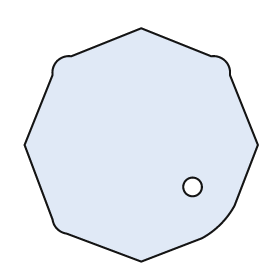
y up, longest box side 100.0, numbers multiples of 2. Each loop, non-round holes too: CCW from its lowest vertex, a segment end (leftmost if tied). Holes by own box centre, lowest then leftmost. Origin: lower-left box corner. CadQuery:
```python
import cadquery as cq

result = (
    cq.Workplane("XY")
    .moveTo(50.0, 0.0)
    .lineTo(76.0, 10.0)
    .threePointArc((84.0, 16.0), (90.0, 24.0))
    .lineTo(100.0, 50.0)
    .lineTo(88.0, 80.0)
    .threePointArc((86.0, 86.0), (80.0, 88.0))
    .lineTo(50.0, 100.0)
    .lineTo(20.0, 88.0)
    .threePointArc((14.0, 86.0), (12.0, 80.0))
    .lineTo(0.0, 50.0)
    .lineTo(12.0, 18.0)
    .threePointArc((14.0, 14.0), (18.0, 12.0))
    .close()
    .moveTo(72.0, 32.0)
    .circle(4.0)
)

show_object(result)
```